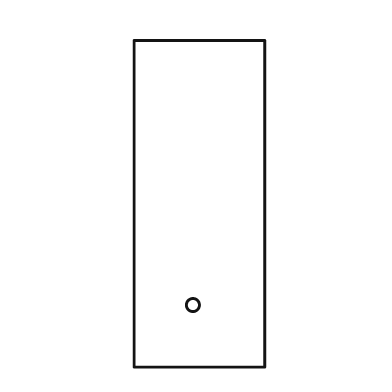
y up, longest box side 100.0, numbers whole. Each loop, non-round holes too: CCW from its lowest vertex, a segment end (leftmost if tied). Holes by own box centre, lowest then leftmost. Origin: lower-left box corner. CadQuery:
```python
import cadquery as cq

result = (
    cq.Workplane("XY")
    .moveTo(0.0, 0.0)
    .lineTo(40.0, 0.0)
    .lineTo(40.0, 100.0)
    .lineTo(0.0, 100.0)
    .close()
    .moveTo(18.0, 19.0)
    .circle(2.0)
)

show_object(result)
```